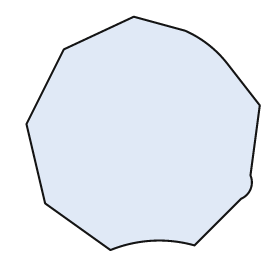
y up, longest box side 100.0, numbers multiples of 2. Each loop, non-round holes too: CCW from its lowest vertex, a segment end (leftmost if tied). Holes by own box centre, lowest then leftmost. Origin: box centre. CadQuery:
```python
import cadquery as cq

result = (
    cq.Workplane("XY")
    .moveTo(-14.0, -50.0)
    .threePointArc((4.0, -46.0), (22.0, -48.0))
    .lineTo(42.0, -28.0)
    .threePointArc((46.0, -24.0), (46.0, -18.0))
    .lineTo(50.0, 12.0)
    .lineTo(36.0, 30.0)
    .threePointArc((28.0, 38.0), (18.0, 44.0))
    .lineTo(-4.0, 50.0)
    .lineTo(-34.0, 36.0)
    .lineTo(-50.0, 4.0)
    .lineTo(-42.0, -30.0)
    .close()
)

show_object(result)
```